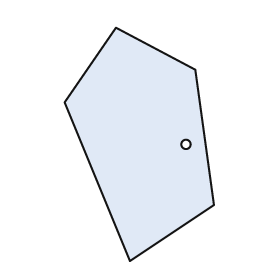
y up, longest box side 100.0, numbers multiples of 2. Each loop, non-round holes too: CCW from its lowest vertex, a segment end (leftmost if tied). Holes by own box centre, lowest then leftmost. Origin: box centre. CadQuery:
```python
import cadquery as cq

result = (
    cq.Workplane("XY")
    .moveTo(-4.0, -50.0)
    .lineTo(32.0, -26.0)
    .lineTo(24.0, 32.0)
    .lineTo(-10.0, 50.0)
    .lineTo(-32.0, 18.0)
    .close()
    .moveTo(20.0, 0.0)
    .circle(2.0)
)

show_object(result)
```